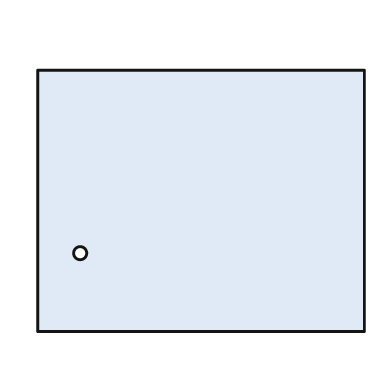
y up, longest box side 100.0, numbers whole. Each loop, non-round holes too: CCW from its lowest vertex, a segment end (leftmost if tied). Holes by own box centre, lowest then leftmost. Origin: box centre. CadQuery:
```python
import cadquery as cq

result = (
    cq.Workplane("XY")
    .moveTo(-50.0, -40.0)
    .lineTo(50.0, -40.0)
    .lineTo(50.0, 40.0)
    .lineTo(-50.0, 40.0)
    .close()
    .moveTo(-37.0, -16.0)
    .circle(2.0)
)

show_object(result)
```